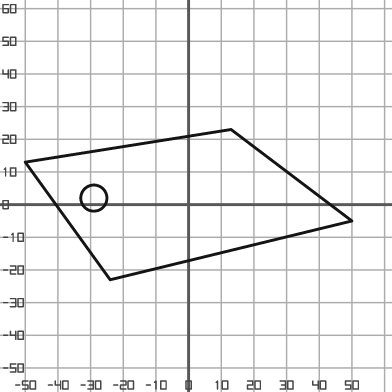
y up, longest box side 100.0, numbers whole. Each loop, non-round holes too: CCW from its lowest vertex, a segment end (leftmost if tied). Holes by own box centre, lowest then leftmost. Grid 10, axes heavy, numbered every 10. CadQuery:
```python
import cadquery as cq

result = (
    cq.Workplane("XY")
    .moveTo(-24.0, -23.0)
    .lineTo(50.0, -5.0)
    .lineTo(13.0, 23.0)
    .lineTo(-50.0, 13.0)
    .close()
    .moveTo(-29.0, 2.0)
    .circle(4.0)
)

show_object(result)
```